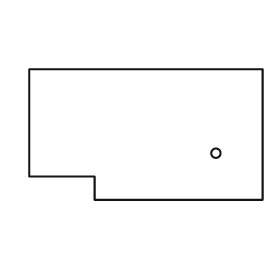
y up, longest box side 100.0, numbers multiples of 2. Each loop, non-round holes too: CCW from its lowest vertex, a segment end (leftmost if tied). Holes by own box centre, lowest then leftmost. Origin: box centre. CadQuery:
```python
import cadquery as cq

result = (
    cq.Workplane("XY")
    .moveTo(-22.0, -28.0)
    .lineTo(50.0, -28.0)
    .lineTo(50.0, 28.0)
    .lineTo(-50.0, 28.0)
    .lineTo(-50.0, -18.0)
    .lineTo(-22.0, -18.0)
    .close()
    .moveTo(30.0, -8.0)
    .circle(2.0)
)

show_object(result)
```